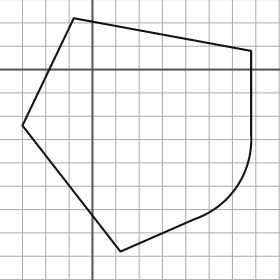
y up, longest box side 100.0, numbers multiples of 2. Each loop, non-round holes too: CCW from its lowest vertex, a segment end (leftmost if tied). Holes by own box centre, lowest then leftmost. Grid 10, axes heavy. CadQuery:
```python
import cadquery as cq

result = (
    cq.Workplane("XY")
    .moveTo(12.0, -78.0)
    .lineTo(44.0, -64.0)
    .threePointArc((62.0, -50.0), (68.0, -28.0))
    .lineTo(68.0, 8.0)
    .lineTo(-8.0, 22.0)
    .lineTo(-30.0, -24.0)
    .close()
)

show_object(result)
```